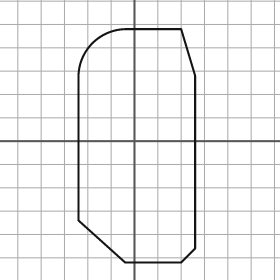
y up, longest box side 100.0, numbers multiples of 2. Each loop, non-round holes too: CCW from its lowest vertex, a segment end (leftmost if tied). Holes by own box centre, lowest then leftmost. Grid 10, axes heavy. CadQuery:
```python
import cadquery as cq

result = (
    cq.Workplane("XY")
    .moveTo(-4.0, -52.0)
    .lineTo(20.0, -52.0)
    .lineTo(26.0, -46.0)
    .lineTo(26.0, 28.0)
    .lineTo(20.0, 48.0)
    .lineTo(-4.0, 48.0)
    .threePointArc((-18.0, 42.0), (-24.0, 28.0))
    .lineTo(-24.0, -34.0)
    .close()
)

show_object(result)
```